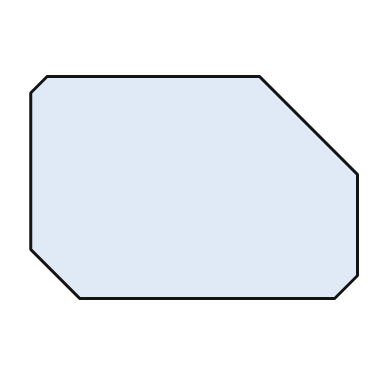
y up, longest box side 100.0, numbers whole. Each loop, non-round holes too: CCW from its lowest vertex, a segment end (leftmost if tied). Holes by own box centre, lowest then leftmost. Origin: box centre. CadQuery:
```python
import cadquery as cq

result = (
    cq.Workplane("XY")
    .moveTo(-35.0, -34.0)
    .lineTo(43.0, -34.0)
    .lineTo(50.0, -27.0)
    .lineTo(50.0, 4.0)
    .lineTo(20.0, 34.0)
    .lineTo(-45.0, 34.0)
    .lineTo(-50.0, 29.0)
    .lineTo(-50.0, -19.0)
    .close()
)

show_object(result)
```